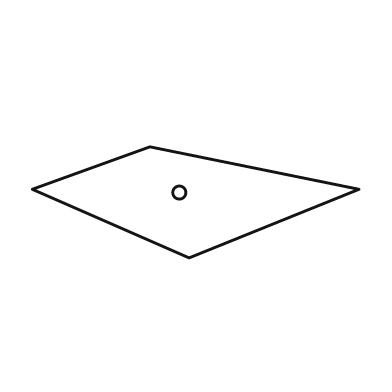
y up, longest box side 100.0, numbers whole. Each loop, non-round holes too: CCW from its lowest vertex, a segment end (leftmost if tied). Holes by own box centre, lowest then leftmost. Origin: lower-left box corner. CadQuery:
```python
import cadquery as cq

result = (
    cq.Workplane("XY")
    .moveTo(48.0, 0.0)
    .lineTo(100.0, 21.0)
    .lineTo(36.0, 34.0)
    .lineTo(0.0, 21.0)
    .close()
    .moveTo(45.0, 20.0)
    .circle(2.0)
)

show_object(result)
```